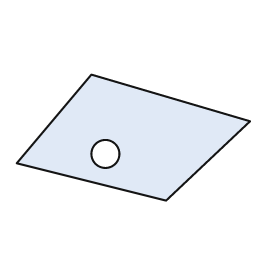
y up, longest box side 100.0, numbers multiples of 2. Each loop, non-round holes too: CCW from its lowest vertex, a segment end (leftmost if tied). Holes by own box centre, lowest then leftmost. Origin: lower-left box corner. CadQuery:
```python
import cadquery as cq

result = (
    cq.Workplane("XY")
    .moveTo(64.0, 0.0)
    .lineTo(100.0, 34.0)
    .lineTo(32.0, 54.0)
    .lineTo(0.0, 16.0)
    .close()
    .moveTo(38.0, 20.0)
    .circle(6.0)
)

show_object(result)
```